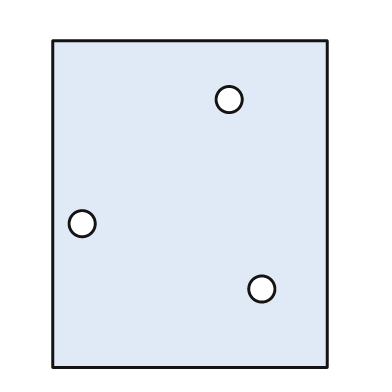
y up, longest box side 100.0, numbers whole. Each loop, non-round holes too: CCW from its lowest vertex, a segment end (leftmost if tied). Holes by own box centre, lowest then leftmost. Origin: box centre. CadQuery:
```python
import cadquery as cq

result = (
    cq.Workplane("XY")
    .moveTo(-42.0, -50.0)
    .lineTo(42.0, -50.0)
    .lineTo(42.0, 50.0)
    .lineTo(-42.0, 50.0)
    .close()
    .moveTo(22.0, -26.0)
    .circle(4.0)
    .moveTo(-33.0, -6.0)
    .circle(4.0)
    .moveTo(12.0, 32.0)
    .circle(4.0)
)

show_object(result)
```